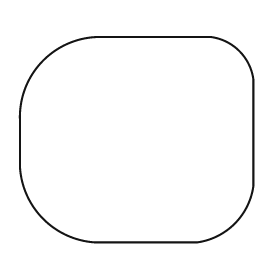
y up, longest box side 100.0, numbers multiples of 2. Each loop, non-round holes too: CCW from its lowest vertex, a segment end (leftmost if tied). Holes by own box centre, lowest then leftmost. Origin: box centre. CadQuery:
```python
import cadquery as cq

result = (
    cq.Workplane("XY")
    .moveTo(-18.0, -44.0)
    .lineTo(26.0, -44.0)
    .threePointArc((42.0, -36.0), (50.0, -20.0))
    .lineTo(50.0, 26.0)
    .threePointArc((44.0, 38.0), (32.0, 44.0))
    .lineTo(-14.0, 44.0)
    .threePointArc((-40.0, 34.0), (-50.0, 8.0))
    .lineTo(-50.0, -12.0)
    .threePointArc((-40.0, -34.0), (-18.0, -44.0))
    .close()
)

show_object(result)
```